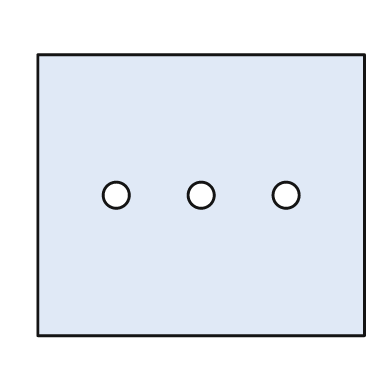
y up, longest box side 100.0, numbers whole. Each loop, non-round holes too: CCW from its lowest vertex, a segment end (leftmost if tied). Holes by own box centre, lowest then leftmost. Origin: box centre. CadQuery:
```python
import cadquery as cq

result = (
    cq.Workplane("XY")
    .moveTo(-50.0, -43.0)
    .lineTo(50.0, -43.0)
    .lineTo(50.0, 43.0)
    .lineTo(-50.0, 43.0)
    .close()
    .moveTo(-26.0, 0.0)
    .circle(4.0)
    .moveTo(0.0, 0.0)
    .circle(4.0)
    .moveTo(26.0, 0.0)
    .circle(4.0)
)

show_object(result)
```